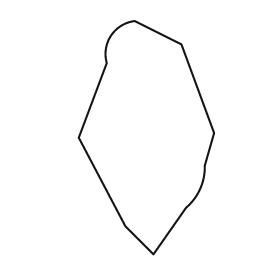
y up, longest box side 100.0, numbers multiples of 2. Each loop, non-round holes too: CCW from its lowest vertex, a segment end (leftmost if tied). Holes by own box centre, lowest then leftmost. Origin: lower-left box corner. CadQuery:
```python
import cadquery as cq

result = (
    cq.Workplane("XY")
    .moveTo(32.0, 0.0)
    .lineTo(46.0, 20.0)
    .threePointArc((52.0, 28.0), (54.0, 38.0))
    .lineTo(58.0, 52.0)
    .lineTo(44.0, 90.0)
    .lineTo(24.0, 100.0)
    .threePointArc((14.0, 94.0), (12.0, 82.0))
    .lineTo(0.0, 50.0)
    .lineTo(20.0, 12.0)
    .close()
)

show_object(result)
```